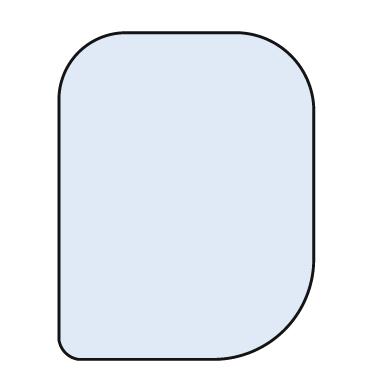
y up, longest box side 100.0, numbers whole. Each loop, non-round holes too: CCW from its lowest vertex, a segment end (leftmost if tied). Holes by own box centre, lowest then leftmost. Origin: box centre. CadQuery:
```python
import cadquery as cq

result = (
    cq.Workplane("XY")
    .moveTo(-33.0, -50.0)
    .lineTo(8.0, -50.0)
    .threePointArc((30.0, -41.0), (39.0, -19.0))
    .lineTo(39.0, 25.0)
    .threePointArc((32.0, 43.0), (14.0, 50.0))
    .lineTo(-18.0, 50.0)
    .threePointArc((-33.0, 44.0), (-39.0, 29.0))
    .lineTo(-39.0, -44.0)
    .threePointArc((-37.0, -48.0), (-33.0, -50.0))
    .close()
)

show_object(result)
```